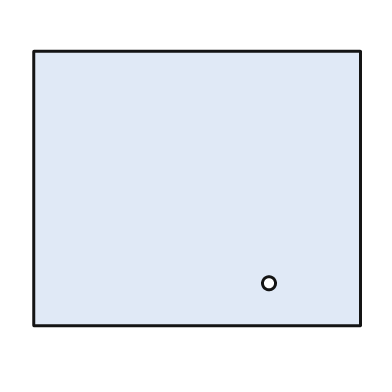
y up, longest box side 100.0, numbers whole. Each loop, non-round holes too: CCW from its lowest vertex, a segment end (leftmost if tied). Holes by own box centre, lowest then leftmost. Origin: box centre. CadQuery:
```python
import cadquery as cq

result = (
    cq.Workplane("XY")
    .moveTo(-50.0, -42.0)
    .lineTo(50.0, -42.0)
    .lineTo(50.0, 42.0)
    .lineTo(-50.0, 42.0)
    .close()
    .moveTo(22.0, -29.0)
    .circle(2.0)
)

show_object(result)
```